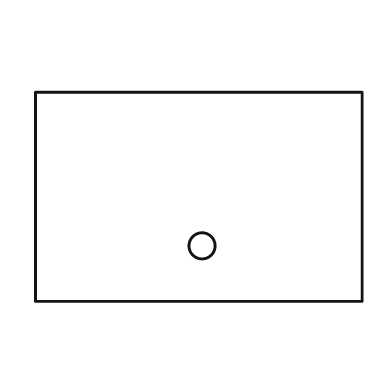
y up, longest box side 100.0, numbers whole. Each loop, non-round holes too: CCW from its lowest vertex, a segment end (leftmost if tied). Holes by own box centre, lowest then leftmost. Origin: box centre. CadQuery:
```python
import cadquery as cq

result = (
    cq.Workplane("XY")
    .moveTo(-50.0, -32.0)
    .lineTo(50.0, -32.0)
    .lineTo(50.0, 32.0)
    .lineTo(-50.0, 32.0)
    .close()
    .moveTo(1.0, -15.0)
    .circle(4.0)
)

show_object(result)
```